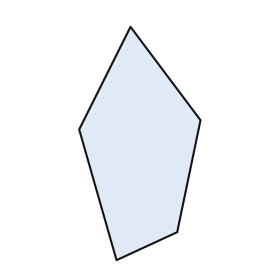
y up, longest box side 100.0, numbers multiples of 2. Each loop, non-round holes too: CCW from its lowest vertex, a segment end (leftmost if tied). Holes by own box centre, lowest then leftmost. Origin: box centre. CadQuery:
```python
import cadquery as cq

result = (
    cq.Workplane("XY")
    .moveTo(-10.0, -50.0)
    .lineTo(16.0, -38.0)
    .lineTo(26.0, 10.0)
    .lineTo(-4.0, 50.0)
    .lineTo(-26.0, 6.0)
    .close()
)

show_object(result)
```